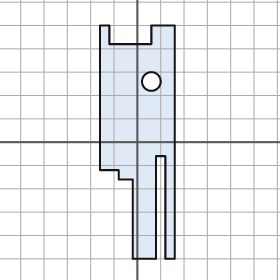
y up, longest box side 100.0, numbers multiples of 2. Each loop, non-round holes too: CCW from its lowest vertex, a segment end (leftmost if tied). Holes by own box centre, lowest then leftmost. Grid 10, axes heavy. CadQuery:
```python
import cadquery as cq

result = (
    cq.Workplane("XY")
    .moveTo(-2.0, -50.0)
    .lineTo(8.0, -50.0)
    .lineTo(8.0, -6.0)
    .lineTo(12.0, -6.0)
    .lineTo(12.0, -50.0)
    .lineTo(16.0, -50.0)
    .lineTo(16.0, 50.0)
    .lineTo(6.0, 50.0)
    .lineTo(6.0, 42.0)
    .lineTo(-12.0, 42.0)
    .lineTo(-12.0, 50.0)
    .lineTo(-16.0, 50.0)
    .lineTo(-16.0, -12.0)
    .lineTo(-8.0, -12.0)
    .lineTo(-8.0, -16.0)
    .lineTo(-2.0, -16.0)
    .close()
    .moveTo(6.0, 26.0)
    .circle(4.0)
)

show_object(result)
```